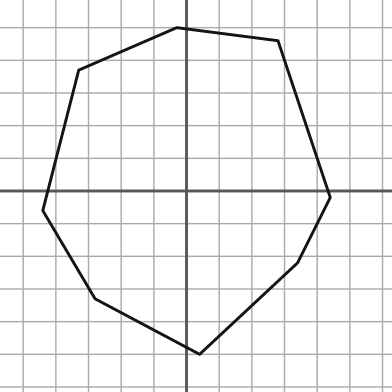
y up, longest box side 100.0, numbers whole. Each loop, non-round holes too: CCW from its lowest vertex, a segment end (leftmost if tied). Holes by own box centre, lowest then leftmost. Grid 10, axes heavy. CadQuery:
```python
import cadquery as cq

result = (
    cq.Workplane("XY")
    .moveTo(4.0, -50.0)
    .lineTo(34.0, -22.0)
    .lineTo(44.0, -2.0)
    .lineTo(28.0, 46.0)
    .lineTo(-3.0, 50.0)
    .lineTo(-33.0, 37.0)
    .lineTo(-44.0, -6.0)
    .lineTo(-28.0, -33.0)
    .close()
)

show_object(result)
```